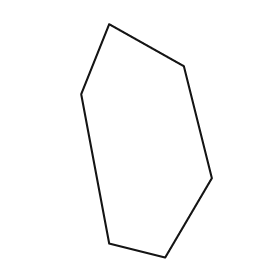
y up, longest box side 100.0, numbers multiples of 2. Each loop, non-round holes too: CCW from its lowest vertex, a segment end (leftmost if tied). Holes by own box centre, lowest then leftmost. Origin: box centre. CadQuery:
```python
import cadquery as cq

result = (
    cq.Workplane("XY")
    .moveTo(8.0, -50.0)
    .lineTo(28.0, -16.0)
    .lineTo(16.0, 32.0)
    .lineTo(-16.0, 50.0)
    .lineTo(-28.0, 20.0)
    .lineTo(-16.0, -44.0)
    .close()
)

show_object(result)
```